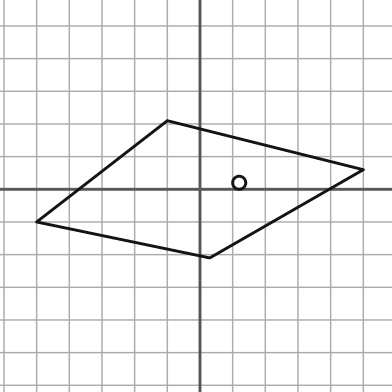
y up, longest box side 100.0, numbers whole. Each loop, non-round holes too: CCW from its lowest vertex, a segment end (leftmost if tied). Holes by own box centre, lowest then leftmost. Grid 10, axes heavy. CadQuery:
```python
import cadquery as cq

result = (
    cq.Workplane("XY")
    .moveTo(3.0, -21.0)
    .lineTo(50.0, 6.0)
    .lineTo(-10.0, 21.0)
    .lineTo(-50.0, -10.0)
    .close()
    .moveTo(12.0, 2.0)
    .circle(2.0)
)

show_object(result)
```